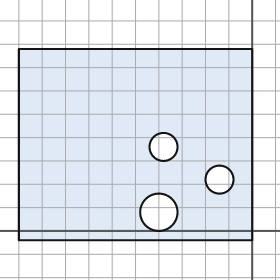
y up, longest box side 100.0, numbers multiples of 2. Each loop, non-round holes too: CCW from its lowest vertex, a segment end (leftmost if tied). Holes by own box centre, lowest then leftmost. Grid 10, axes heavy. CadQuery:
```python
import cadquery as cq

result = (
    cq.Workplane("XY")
    .moveTo(-100.0, -4.0)
    .lineTo(0.0, -4.0)
    .lineTo(0.0, 78.0)
    .lineTo(-100.0, 78.0)
    .close()
    .moveTo(-40.0, 8.0)
    .circle(8.0)
    .moveTo(-14.0, 22.0)
    .circle(6.0)
    .moveTo(-38.0, 36.0)
    .circle(6.0)
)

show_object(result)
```